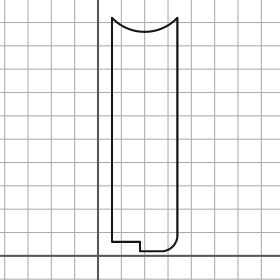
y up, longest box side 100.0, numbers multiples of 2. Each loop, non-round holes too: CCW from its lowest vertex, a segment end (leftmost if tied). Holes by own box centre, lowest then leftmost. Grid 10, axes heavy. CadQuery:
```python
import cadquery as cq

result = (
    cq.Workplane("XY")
    .moveTo(18.0, 2.0)
    .lineTo(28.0, 2.0)
    .threePointArc((32.0, 4.0), (34.0, 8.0))
    .lineTo(34.0, 102.0)
    .threePointArc((20.0, 96.0), (6.0, 102.0))
    .lineTo(6.0, 6.0)
    .lineTo(18.0, 6.0)
    .close()
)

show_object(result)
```